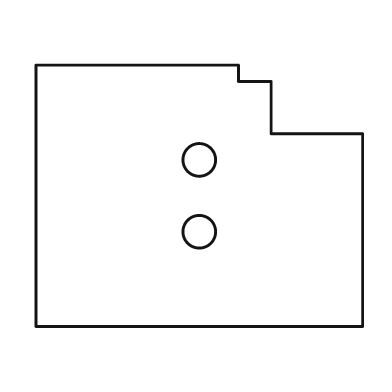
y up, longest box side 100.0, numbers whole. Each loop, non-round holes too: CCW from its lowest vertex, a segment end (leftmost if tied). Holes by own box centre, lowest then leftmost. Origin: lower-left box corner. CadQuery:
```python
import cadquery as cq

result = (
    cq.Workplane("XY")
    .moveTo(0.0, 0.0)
    .lineTo(100.0, 0.0)
    .lineTo(100.0, 59.0)
    .lineTo(72.0, 59.0)
    .lineTo(72.0, 75.0)
    .lineTo(62.0, 75.0)
    .lineTo(62.0, 80.0)
    .lineTo(0.0, 80.0)
    .close()
    .moveTo(50.0, 29.0)
    .circle(5.0)
    .moveTo(50.0, 51.0)
    .circle(5.0)
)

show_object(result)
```